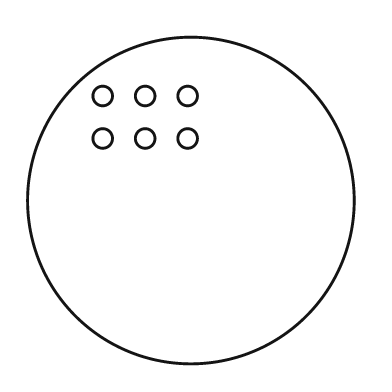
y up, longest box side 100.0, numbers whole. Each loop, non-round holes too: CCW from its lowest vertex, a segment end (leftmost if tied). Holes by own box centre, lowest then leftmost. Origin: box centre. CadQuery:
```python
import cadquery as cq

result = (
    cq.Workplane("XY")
    .moveTo(0.0, 0.0)
    .circle(50.0)
    .moveTo(-27.0, 19.0)
    .circle(3.0)
    .moveTo(-14.0, 19.0)
    .circle(3.0)
    .moveTo(-1.0, 19.0)
    .circle(3.0)
    .moveTo(-27.0, 32.0)
    .circle(3.0)
    .moveTo(-14.0, 32.0)
    .circle(3.0)
    .moveTo(-1.0, 32.0)
    .circle(3.0)
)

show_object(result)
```